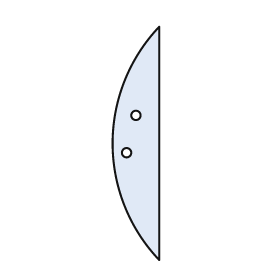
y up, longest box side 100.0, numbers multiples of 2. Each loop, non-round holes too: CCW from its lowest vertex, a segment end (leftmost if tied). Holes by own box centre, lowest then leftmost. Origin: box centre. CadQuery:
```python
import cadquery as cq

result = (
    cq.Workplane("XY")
    .moveTo(10.0, -50.0)
    .lineTo(10.0, 50.0)
    .threePointArc((-10.0, 0.0), (10.0, -50.0))
    .close()
    .moveTo(-4.0, -4.0)
    .circle(2.0)
    .moveTo(0.0, 12.0)
    .circle(2.0)
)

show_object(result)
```